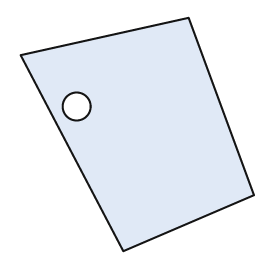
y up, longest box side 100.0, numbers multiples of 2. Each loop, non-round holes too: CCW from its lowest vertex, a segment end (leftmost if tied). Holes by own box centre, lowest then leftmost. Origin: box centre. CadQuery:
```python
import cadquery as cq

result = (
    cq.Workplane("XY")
    .moveTo(-6.0, -50.0)
    .lineTo(50.0, -26.0)
    .lineTo(22.0, 50.0)
    .lineTo(-50.0, 34.0)
    .close()
    .moveTo(-26.0, 12.0)
    .circle(6.0)
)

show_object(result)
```